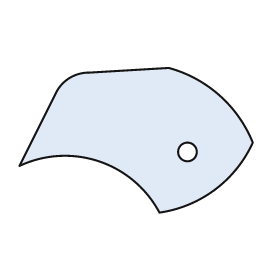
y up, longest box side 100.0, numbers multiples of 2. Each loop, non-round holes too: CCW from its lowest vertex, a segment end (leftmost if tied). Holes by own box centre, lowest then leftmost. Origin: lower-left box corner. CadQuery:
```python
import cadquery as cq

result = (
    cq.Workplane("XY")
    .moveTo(60.0, 0.0)
    .threePointArc((84.0, 10.0), (100.0, 30.0))
    .threePointArc((86.0, 50.0), (64.0, 62.0))
    .lineTo(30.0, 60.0)
    .threePointArc((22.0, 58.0), (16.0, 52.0))
    .lineTo(0.0, 20.0)
    .threePointArc((34.0, 22.0), (60.0, 0.0))
    .close()
    .moveTo(72.0, 26.0)
    .circle(4.0)
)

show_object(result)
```